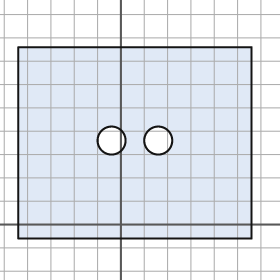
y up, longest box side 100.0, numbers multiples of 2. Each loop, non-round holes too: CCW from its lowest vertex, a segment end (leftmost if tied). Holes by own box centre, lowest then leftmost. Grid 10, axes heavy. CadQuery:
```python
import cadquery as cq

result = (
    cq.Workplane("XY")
    .moveTo(-44.0, -6.0)
    .lineTo(56.0, -6.0)
    .lineTo(56.0, 76.0)
    .lineTo(-44.0, 76.0)
    .close()
    .moveTo(-4.0, 36.0)
    .circle(6.0)
    .moveTo(16.0, 36.0)
    .circle(6.0)
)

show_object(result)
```